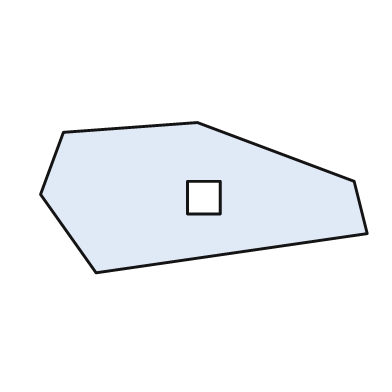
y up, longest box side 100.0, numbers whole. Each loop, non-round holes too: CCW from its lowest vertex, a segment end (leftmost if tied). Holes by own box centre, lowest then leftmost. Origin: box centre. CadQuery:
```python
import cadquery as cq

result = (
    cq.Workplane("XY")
    .moveTo(-33.0, -23.0)
    .lineTo(50.0, -11.0)
    .lineTo(46.0, 5.0)
    .lineTo(-2.0, 23.0)
    .lineTo(-43.0, 20.0)
    .lineTo(-50.0, 1.0)
    .close()
    .moveTo(-5.0, -5.0)
    .lineTo(5.0, -5.0)
    .lineTo(5.0, 5.0)
    .lineTo(-5.0, 5.0)
    .close()
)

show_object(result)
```